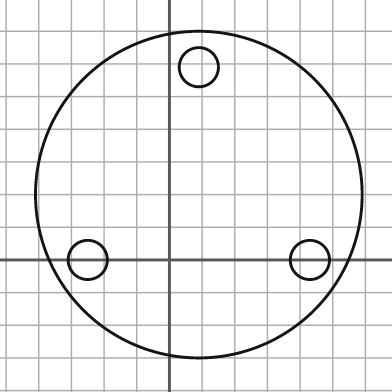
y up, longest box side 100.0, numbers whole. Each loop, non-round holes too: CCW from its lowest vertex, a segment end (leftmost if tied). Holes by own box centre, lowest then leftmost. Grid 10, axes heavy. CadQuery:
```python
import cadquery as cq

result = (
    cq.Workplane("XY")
    .moveTo(9.0, 20.0)
    .circle(50.0)
    .moveTo(-25.0, 0.0)
    .circle(6.0)
    .moveTo(43.0, 0.0)
    .circle(6.0)
    .moveTo(9.0, 59.0)
    .circle(6.0)
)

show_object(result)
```